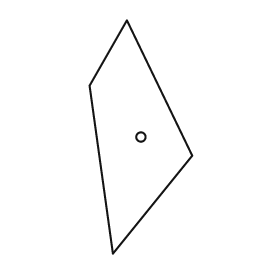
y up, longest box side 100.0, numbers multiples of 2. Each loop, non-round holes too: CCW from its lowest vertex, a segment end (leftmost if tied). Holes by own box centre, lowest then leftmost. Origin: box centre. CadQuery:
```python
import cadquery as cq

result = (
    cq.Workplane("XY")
    .moveTo(-12.0, -50.0)
    .lineTo(22.0, -8.0)
    .lineTo(-6.0, 50.0)
    .lineTo(-22.0, 22.0)
    .close()
    .moveTo(0.0, 0.0)
    .circle(2.0)
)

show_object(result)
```